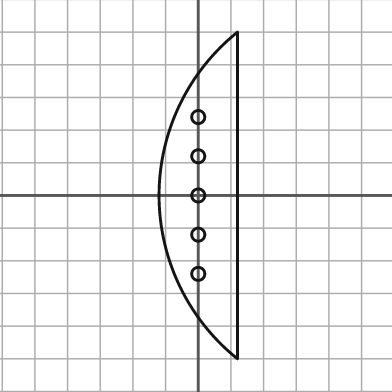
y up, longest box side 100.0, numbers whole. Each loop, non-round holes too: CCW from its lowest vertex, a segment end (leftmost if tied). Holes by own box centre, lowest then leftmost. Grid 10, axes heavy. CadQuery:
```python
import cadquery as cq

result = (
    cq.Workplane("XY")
    .moveTo(12.0, -50.0)
    .lineTo(12.0, 50.0)
    .threePointArc((-12.0, 0.0), (12.0, -50.0))
    .close()
    .moveTo(0.0, -24.0)
    .circle(2.0)
    .moveTo(0.0, -12.0)
    .circle(2.0)
    .moveTo(0.0, 0.0)
    .circle(2.0)
    .moveTo(0.0, 12.0)
    .circle(2.0)
    .moveTo(0.0, 24.0)
    .circle(2.0)
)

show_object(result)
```